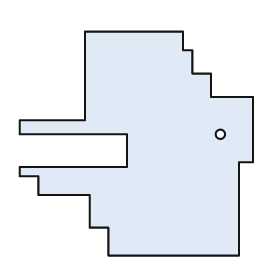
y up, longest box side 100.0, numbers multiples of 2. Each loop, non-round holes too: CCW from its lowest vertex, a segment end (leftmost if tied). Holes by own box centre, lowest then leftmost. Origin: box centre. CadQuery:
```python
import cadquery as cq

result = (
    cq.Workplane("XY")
    .moveTo(-12.0, -48.0)
    .lineTo(44.0, -48.0)
    .lineTo(44.0, -8.0)
    .lineTo(50.0, -8.0)
    .lineTo(50.0, 20.0)
    .lineTo(32.0, 20.0)
    .lineTo(32.0, 30.0)
    .lineTo(24.0, 30.0)
    .lineTo(24.0, 40.0)
    .lineTo(20.0, 40.0)
    .lineTo(20.0, 48.0)
    .lineTo(-22.0, 48.0)
    .lineTo(-22.0, 10.0)
    .lineTo(-50.0, 10.0)
    .lineTo(-50.0, 4.0)
    .lineTo(-4.0, 4.0)
    .lineTo(-4.0, -10.0)
    .lineTo(-50.0, -10.0)
    .lineTo(-50.0, -14.0)
    .lineTo(-42.0, -14.0)
    .lineTo(-42.0, -22.0)
    .lineTo(-20.0, -22.0)
    .lineTo(-20.0, -36.0)
    .lineTo(-12.0, -36.0)
    .close()
    .moveTo(36.0, 4.0)
    .circle(2.0)
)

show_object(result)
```